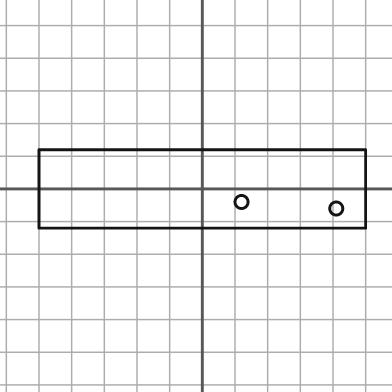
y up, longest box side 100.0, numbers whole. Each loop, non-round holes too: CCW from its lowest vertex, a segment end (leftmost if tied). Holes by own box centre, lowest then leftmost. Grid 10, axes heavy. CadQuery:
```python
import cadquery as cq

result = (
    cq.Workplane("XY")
    .moveTo(-50.0, -12.0)
    .lineTo(50.0, -12.0)
    .lineTo(50.0, 12.0)
    .lineTo(-50.0, 12.0)
    .close()
    .moveTo(41.0, -6.0)
    .circle(2.0)
    .moveTo(12.0, -4.0)
    .circle(2.0)
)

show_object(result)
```